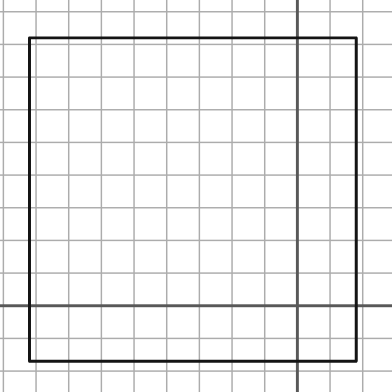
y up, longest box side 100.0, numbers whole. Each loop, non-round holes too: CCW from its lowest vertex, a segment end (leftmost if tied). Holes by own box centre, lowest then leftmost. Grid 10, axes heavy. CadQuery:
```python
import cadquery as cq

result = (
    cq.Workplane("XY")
    .moveTo(-82.0, -17.0)
    .lineTo(18.0, -17.0)
    .lineTo(18.0, 82.0)
    .lineTo(-82.0, 82.0)
    .close()
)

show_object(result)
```